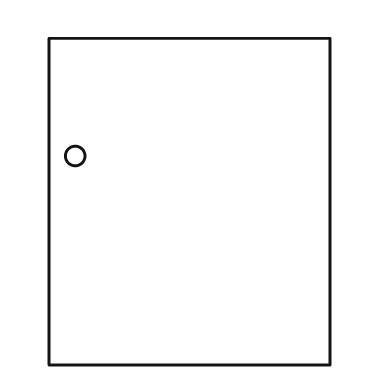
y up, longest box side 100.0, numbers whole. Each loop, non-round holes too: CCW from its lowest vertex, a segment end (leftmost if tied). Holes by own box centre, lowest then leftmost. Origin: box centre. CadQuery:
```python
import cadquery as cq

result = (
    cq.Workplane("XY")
    .moveTo(-43.0, -50.0)
    .lineTo(43.0, -50.0)
    .lineTo(43.0, 50.0)
    .lineTo(-43.0, 50.0)
    .close()
    .moveTo(-35.0, 14.0)
    .circle(3.0)
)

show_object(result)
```